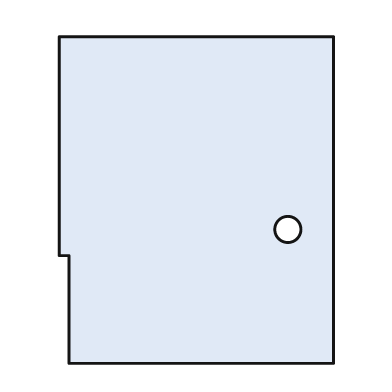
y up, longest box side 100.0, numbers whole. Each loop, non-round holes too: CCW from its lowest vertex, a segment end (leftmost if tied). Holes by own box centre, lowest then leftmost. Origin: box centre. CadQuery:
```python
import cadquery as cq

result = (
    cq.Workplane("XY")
    .moveTo(-39.0, -50.0)
    .lineTo(42.0, -50.0)
    .lineTo(42.0, 50.0)
    .lineTo(-42.0, 50.0)
    .lineTo(-42.0, -17.0)
    .lineTo(-39.0, -17.0)
    .close()
    .moveTo(28.0, -9.0)
    .circle(4.0)
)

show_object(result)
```